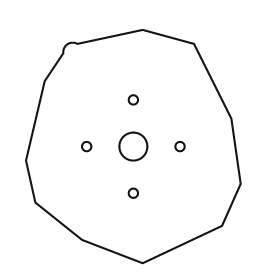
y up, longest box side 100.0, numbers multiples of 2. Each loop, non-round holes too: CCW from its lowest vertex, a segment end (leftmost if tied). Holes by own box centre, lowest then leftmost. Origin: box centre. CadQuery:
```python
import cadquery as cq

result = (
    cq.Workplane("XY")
    .moveTo(4.0, -50.0)
    .lineTo(38.0, -34.0)
    .lineTo(46.0, -16.0)
    .lineTo(42.0, 12.0)
    .lineTo(26.0, 44.0)
    .lineTo(4.0, 50.0)
    .lineTo(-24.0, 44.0)
    .threePointArc((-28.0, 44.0), (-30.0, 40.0))
    .lineTo(-38.0, 28.0)
    .lineTo(-46.0, -6.0)
    .lineTo(-42.0, -24.0)
    .lineTo(-22.0, -40.0)
    .close()
    .moveTo(0.0, -20.0)
    .circle(2.0)
    .moveTo(-20.0, 0.0)
    .circle(2.0)
    .moveTo(0.0, 0.0)
    .circle(6.0)
    .moveTo(20.0, 0.0)
    .circle(2.0)
    .moveTo(0.0, 20.0)
    .circle(2.0)
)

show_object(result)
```